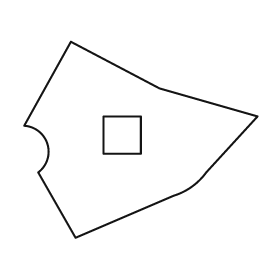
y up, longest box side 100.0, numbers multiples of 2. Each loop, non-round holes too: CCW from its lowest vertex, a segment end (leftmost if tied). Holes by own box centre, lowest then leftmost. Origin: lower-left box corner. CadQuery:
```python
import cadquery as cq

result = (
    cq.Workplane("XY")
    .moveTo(22.0, 0.0)
    .lineTo(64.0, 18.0)
    .threePointArc((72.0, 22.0), (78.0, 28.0))
    .lineTo(100.0, 52.0)
    .lineTo(58.0, 64.0)
    .lineTo(20.0, 84.0)
    .lineTo(0.0, 48.0)
    .threePointArc((10.0, 40.0), (6.0, 28.0))
    .close()
    .moveTo(34.0, 36.0)
    .lineTo(50.0, 36.0)
    .lineTo(50.0, 52.0)
    .lineTo(34.0, 52.0)
    .close()
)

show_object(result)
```